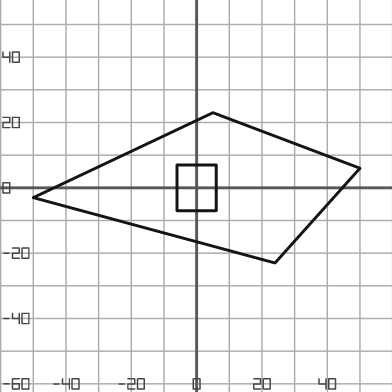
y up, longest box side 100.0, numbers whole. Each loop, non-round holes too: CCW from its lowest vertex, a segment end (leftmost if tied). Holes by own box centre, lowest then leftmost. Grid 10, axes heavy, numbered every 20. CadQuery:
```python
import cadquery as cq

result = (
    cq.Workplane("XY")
    .moveTo(24.0, -23.0)
    .lineTo(50.0, 6.0)
    .lineTo(5.0, 23.0)
    .lineTo(-50.0, -3.0)
    .close()
    .moveTo(-6.0, -7.0)
    .lineTo(6.0, -7.0)
    .lineTo(6.0, 7.0)
    .lineTo(-6.0, 7.0)
    .close()
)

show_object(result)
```